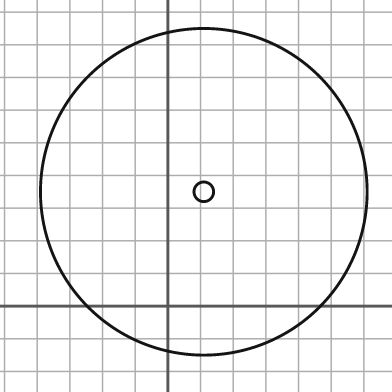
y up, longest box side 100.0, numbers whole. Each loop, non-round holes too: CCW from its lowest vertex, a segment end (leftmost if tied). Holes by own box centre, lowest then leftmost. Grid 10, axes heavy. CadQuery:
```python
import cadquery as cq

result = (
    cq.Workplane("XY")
    .moveTo(11.0, 35.0)
    .circle(50.0)
    .moveTo(11.0, 35.0)
    .circle(3.0)
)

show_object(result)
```